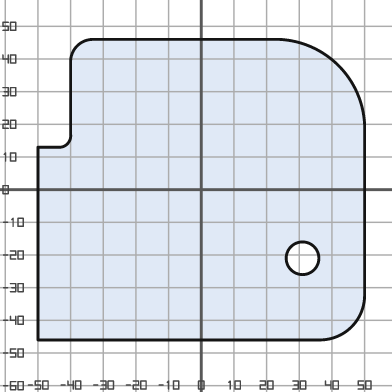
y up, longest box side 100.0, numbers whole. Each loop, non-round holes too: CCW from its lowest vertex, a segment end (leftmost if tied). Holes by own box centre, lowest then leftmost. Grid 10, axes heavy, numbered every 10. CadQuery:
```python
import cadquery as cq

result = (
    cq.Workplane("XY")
    .moveTo(-50.0, -46.0)
    .lineTo(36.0, -46.0)
    .threePointArc((46.0, -42.0), (50.0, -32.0))
    .lineTo(50.0, 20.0)
    .threePointArc((42.0, 38.0), (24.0, 46.0))
    .lineTo(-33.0, 46.0)
    .threePointArc((-38.0, 44.0), (-40.0, 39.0))
    .lineTo(-40.0, 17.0)
    .threePointArc((-41.0, 14.0), (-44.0, 13.0))
    .lineTo(-50.0, 13.0)
    .close()
    .moveTo(31.0, -21.0)
    .circle(5.0)
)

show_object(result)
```